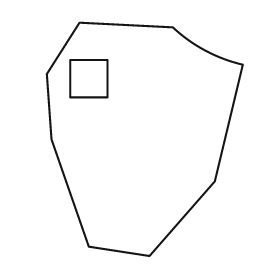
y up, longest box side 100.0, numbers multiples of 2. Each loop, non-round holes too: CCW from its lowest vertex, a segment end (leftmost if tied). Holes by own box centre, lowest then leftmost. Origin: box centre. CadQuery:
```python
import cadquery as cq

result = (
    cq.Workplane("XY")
    .moveTo(2.0, -50.0)
    .lineTo(30.0, -18.0)
    .lineTo(42.0, 32.0)
    .threePointArc((26.0, 38.0), (12.0, 48.0))
    .lineTo(-28.0, 50.0)
    .lineTo(-42.0, 28.0)
    .lineTo(-40.0, 0.0)
    .lineTo(-24.0, -46.0)
    .close()
    .moveTo(-32.0, 18.0)
    .lineTo(-16.0, 18.0)
    .lineTo(-16.0, 34.0)
    .lineTo(-32.0, 34.0)
    .close()
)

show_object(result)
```